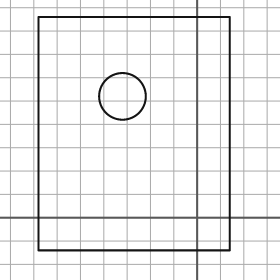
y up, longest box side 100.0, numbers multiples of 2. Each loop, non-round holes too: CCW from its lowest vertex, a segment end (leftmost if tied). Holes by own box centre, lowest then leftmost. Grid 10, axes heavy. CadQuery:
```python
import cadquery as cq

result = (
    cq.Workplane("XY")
    .moveTo(-68.0, -14.0)
    .lineTo(14.0, -14.0)
    .lineTo(14.0, 86.0)
    .lineTo(-68.0, 86.0)
    .close()
    .moveTo(-32.0, 52.0)
    .circle(10.0)
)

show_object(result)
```